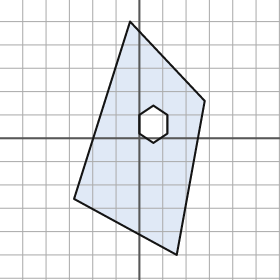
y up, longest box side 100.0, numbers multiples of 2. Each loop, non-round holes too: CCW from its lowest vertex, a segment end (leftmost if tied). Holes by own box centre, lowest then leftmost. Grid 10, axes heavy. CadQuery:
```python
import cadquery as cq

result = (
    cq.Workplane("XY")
    .moveTo(16.0, -50.0)
    .lineTo(28.0, 16.0)
    .lineTo(-4.0, 50.0)
    .lineTo(-28.0, -26.0)
    .close()
    .moveTo(6.0, -2.0)
    .lineTo(12.0, 2.0)
    .lineTo(12.0, 10.0)
    .lineTo(6.0, 14.0)
    .lineTo(0.0, 10.0)
    .lineTo(0.0, 2.0)
    .close()
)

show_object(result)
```